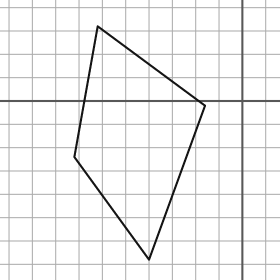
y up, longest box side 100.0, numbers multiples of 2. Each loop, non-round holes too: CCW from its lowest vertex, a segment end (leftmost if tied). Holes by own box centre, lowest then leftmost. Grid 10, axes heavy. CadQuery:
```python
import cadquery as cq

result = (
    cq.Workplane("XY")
    .moveTo(-40.0, -68.0)
    .lineTo(-16.0, -2.0)
    .lineTo(-62.0, 32.0)
    .lineTo(-72.0, -24.0)
    .close()
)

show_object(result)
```